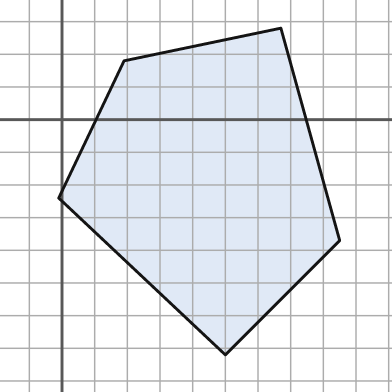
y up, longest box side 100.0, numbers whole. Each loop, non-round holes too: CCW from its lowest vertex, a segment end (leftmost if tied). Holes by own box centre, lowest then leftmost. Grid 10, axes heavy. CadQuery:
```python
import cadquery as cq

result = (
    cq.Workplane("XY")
    .moveTo(50.0, -72.0)
    .lineTo(85.0, -37.0)
    .lineTo(67.0, 28.0)
    .lineTo(19.0, 18.0)
    .lineTo(-1.0, -24.0)
    .close()
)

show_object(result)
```